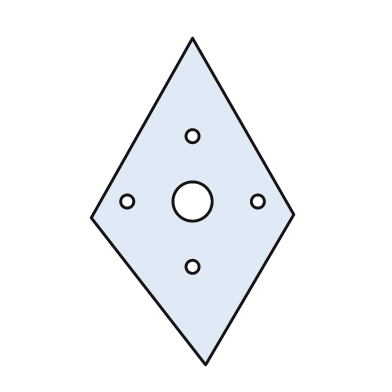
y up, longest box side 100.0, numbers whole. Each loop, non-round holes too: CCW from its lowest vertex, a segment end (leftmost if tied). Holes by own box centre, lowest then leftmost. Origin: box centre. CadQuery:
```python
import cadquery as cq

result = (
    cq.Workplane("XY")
    .moveTo(4.0, -50.0)
    .lineTo(31.0, -4.0)
    .lineTo(0.0, 50.0)
    .lineTo(-31.0, -5.0)
    .close()
    .moveTo(0.0, -20.0)
    .circle(2.0)
    .moveTo(-20.0, 0.0)
    .circle(2.0)
    .moveTo(0.0, 0.0)
    .circle(6.0)
    .moveTo(20.0, 0.0)
    .circle(2.0)
    .moveTo(0.0, 20.0)
    .circle(2.0)
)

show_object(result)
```